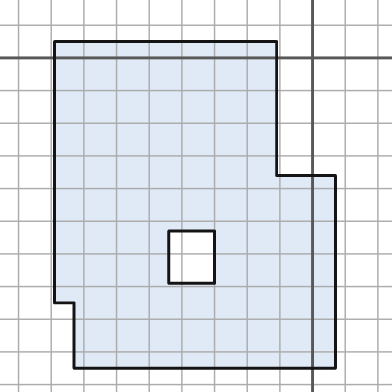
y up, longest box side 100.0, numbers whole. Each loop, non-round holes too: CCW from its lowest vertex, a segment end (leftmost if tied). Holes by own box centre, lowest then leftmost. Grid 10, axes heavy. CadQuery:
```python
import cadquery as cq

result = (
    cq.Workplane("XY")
    .moveTo(-73.0, -95.0)
    .lineTo(7.0, -95.0)
    .lineTo(7.0, -36.0)
    .lineTo(-11.0, -36.0)
    .lineTo(-11.0, 5.0)
    .lineTo(-79.0, 5.0)
    .lineTo(-79.0, -75.0)
    .lineTo(-73.0, -75.0)
    .close()
    .moveTo(-44.0, -69.0)
    .lineTo(-30.0, -69.0)
    .lineTo(-30.0, -53.0)
    .lineTo(-44.0, -53.0)
    .close()
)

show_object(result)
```